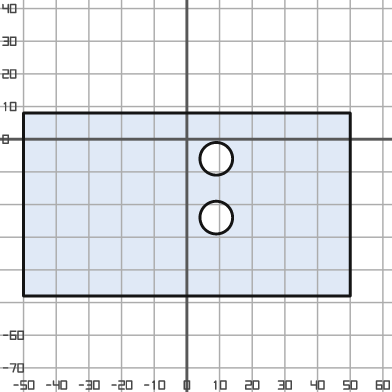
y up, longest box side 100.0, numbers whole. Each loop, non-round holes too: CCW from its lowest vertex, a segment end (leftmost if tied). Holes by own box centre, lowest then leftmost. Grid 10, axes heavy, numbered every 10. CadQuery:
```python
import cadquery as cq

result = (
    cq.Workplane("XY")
    .moveTo(-50.0, -48.0)
    .lineTo(50.0, -48.0)
    .lineTo(50.0, 8.0)
    .lineTo(-50.0, 8.0)
    .close()
    .moveTo(9.0, -24.0)
    .circle(5.0)
    .moveTo(9.0, -6.0)
    .circle(5.0)
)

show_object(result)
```